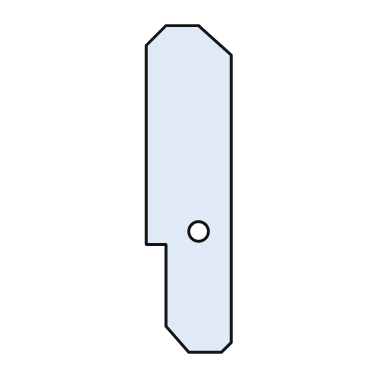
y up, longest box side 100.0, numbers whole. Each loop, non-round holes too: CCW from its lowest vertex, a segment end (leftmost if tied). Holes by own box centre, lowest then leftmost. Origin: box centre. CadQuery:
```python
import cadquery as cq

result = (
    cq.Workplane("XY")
    .moveTo(0.0, -50.0)
    .lineTo(10.0, -50.0)
    .lineTo(13.0, -47.0)
    .lineTo(13.0, 41.0)
    .lineTo(3.0, 50.0)
    .lineTo(-7.0, 50.0)
    .lineTo(-13.0, 44.0)
    .lineTo(-13.0, -17.0)
    .lineTo(-7.0, -17.0)
    .lineTo(-7.0, -42.0)
    .close()
    .moveTo(3.0, -13.0)
    .circle(3.0)
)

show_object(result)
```